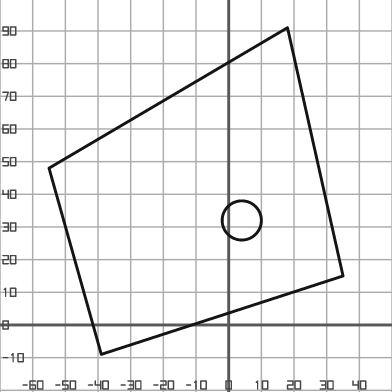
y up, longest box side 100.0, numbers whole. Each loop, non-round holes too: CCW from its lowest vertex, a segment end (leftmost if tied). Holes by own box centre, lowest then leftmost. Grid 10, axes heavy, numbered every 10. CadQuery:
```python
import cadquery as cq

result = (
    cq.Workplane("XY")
    .moveTo(-39.0, -9.0)
    .lineTo(35.0, 15.0)
    .lineTo(18.0, 91.0)
    .lineTo(-55.0, 48.0)
    .close()
    .moveTo(4.0, 32.0)
    .circle(6.0)
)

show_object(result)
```